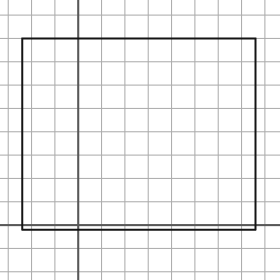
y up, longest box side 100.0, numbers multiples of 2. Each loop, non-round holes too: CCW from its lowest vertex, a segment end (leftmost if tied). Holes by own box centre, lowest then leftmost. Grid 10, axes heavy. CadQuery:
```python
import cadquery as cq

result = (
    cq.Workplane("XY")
    .moveTo(-24.0, -2.0)
    .lineTo(76.0, -2.0)
    .lineTo(76.0, 80.0)
    .lineTo(-24.0, 80.0)
    .close()
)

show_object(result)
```